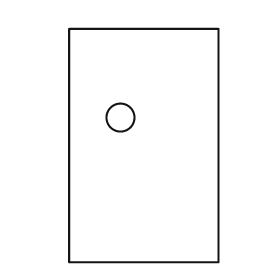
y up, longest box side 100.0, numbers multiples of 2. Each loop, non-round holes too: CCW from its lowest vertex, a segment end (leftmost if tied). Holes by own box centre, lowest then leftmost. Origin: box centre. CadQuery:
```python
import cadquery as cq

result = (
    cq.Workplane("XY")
    .moveTo(-32.0, -50.0)
    .lineTo(32.0, -50.0)
    .lineTo(32.0, 50.0)
    .lineTo(-32.0, 50.0)
    .close()
    .moveTo(-10.0, 12.0)
    .circle(6.0)
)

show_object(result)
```